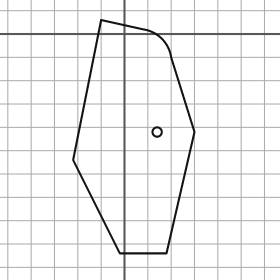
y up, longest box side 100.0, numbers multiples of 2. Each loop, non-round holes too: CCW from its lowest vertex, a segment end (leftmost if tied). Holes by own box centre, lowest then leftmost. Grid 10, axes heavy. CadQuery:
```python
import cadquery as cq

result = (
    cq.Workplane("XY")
    .moveTo(-2.0, -94.0)
    .lineTo(18.0, -94.0)
    .lineTo(30.0, -42.0)
    .lineTo(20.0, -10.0)
    .threePointArc((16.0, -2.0), (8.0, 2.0))
    .lineTo(-10.0, 6.0)
    .lineTo(-22.0, -54.0)
    .close()
    .moveTo(14.0, -42.0)
    .circle(2.0)
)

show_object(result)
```